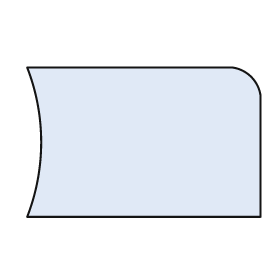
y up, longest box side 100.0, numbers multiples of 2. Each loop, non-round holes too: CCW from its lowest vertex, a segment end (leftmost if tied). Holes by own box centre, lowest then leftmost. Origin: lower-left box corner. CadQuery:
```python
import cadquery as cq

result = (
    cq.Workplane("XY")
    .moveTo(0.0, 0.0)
    .lineTo(100.0, 0.0)
    .lineTo(100.0, 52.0)
    .threePointArc((96.0, 60.0), (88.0, 64.0))
    .lineTo(0.0, 64.0)
    .threePointArc((6.0, 32.0), (0.0, 0.0))
    .close()
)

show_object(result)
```